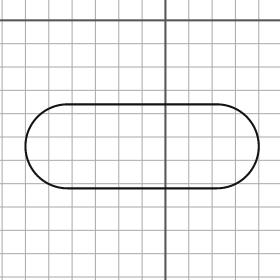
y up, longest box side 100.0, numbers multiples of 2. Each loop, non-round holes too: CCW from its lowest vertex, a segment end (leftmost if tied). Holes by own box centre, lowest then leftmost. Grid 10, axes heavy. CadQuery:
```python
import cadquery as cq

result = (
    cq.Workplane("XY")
    .moveTo(-42.0, -72.0)
    .lineTo(22.0, -72.0)
    .threePointArc((40.0, -54.0), (22.0, -36.0))
    .lineTo(-42.0, -36.0)
    .threePointArc((-60.0, -54.0), (-42.0, -72.0))
    .close()
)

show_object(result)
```